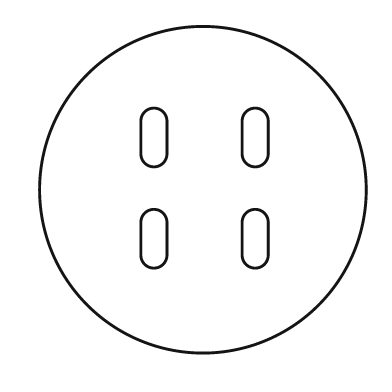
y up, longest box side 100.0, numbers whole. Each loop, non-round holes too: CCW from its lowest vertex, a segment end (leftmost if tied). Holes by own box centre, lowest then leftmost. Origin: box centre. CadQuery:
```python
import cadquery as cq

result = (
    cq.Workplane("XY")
    .moveTo(0.0, 0.0)
    .circle(50.0)
    .moveTo(-19.0, -20.0)
    .threePointArc((-15.0, -24.0), (-11.0, -20.0))
    .lineTo(-11.0, -10.0)
    .threePointArc((-15.0, -6.0), (-19.0, -10.0))
    .close()
    .moveTo(12.0, -20.0)
    .threePointArc((16.0, -24.0), (20.0, -20.0))
    .lineTo(20.0, -10.0)
    .threePointArc((16.0, -6.0), (12.0, -10.0))
    .close()
    .moveTo(-19.0, 11.0)
    .threePointArc((-15.0, 7.0), (-11.0, 11.0))
    .lineTo(-11.0, 21.0)
    .threePointArc((-15.0, 25.0), (-19.0, 21.0))
    .close()
    .moveTo(12.0, 11.0)
    .threePointArc((16.0, 7.0), (20.0, 11.0))
    .lineTo(20.0, 21.0)
    .threePointArc((16.0, 25.0), (12.0, 21.0))
    .close()
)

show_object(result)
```